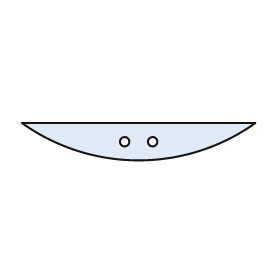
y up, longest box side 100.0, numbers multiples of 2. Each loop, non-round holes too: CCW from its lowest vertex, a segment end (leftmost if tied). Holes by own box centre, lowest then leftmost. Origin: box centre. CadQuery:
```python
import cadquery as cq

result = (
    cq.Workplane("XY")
    .moveTo(-50.0, 8.0)
    .threePointArc((0.0, -8.0), (50.0, 8.0))
    .close()
    .moveTo(-6.0, 0.0)
    .circle(2.0)
    .moveTo(6.0, 0.0)
    .circle(2.0)
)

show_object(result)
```